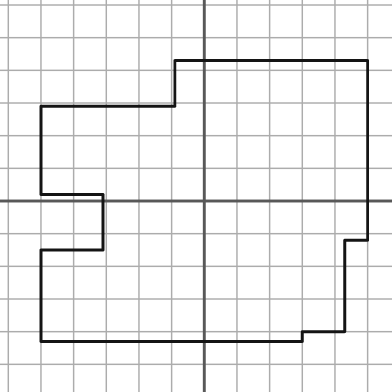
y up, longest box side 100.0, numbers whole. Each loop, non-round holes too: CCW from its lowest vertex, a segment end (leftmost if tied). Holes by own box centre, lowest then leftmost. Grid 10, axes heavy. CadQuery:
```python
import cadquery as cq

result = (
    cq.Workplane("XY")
    .moveTo(-50.0, -43.0)
    .lineTo(30.0, -43.0)
    .lineTo(30.0, -40.0)
    .lineTo(43.0, -40.0)
    .lineTo(43.0, -12.0)
    .lineTo(50.0, -12.0)
    .lineTo(50.0, 43.0)
    .lineTo(-9.0, 43.0)
    .lineTo(-9.0, 29.0)
    .lineTo(-50.0, 29.0)
    .lineTo(-50.0, 2.0)
    .lineTo(-31.0, 2.0)
    .lineTo(-31.0, -15.0)
    .lineTo(-50.0, -15.0)
    .close()
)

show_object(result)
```